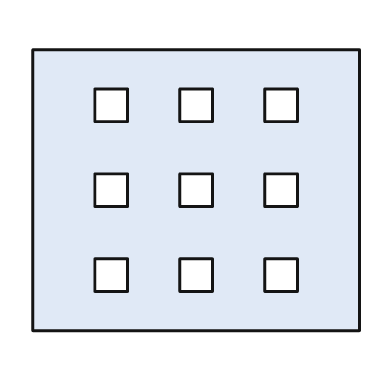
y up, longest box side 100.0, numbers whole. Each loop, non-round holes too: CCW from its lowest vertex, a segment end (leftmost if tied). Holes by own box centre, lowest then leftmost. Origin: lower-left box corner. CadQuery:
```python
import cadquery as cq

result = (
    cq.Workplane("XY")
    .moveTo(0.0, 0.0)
    .lineTo(100.0, 0.0)
    .lineTo(100.0, 86.0)
    .lineTo(0.0, 86.0)
    .close()
    .moveTo(19.0, 12.0)
    .lineTo(29.0, 12.0)
    .lineTo(29.0, 22.0)
    .lineTo(19.0, 22.0)
    .close()
    .moveTo(45.0, 12.0)
    .lineTo(55.0, 12.0)
    .lineTo(55.0, 22.0)
    .lineTo(45.0, 22.0)
    .close()
    .moveTo(71.0, 12.0)
    .lineTo(81.0, 12.0)
    .lineTo(81.0, 22.0)
    .lineTo(71.0, 22.0)
    .close()
    .moveTo(19.0, 38.0)
    .lineTo(29.0, 38.0)
    .lineTo(29.0, 48.0)
    .lineTo(19.0, 48.0)
    .close()
    .moveTo(45.0, 38.0)
    .lineTo(55.0, 38.0)
    .lineTo(55.0, 48.0)
    .lineTo(45.0, 48.0)
    .close()
    .moveTo(71.0, 38.0)
    .lineTo(81.0, 38.0)
    .lineTo(81.0, 48.0)
    .lineTo(71.0, 48.0)
    .close()
    .moveTo(19.0, 64.0)
    .lineTo(29.0, 64.0)
    .lineTo(29.0, 74.0)
    .lineTo(19.0, 74.0)
    .close()
    .moveTo(45.0, 64.0)
    .lineTo(55.0, 64.0)
    .lineTo(55.0, 74.0)
    .lineTo(45.0, 74.0)
    .close()
    .moveTo(71.0, 64.0)
    .lineTo(81.0, 64.0)
    .lineTo(81.0, 74.0)
    .lineTo(71.0, 74.0)
    .close()
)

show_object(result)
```